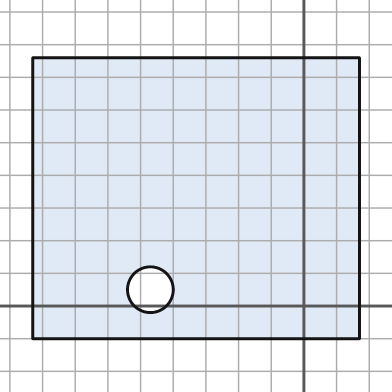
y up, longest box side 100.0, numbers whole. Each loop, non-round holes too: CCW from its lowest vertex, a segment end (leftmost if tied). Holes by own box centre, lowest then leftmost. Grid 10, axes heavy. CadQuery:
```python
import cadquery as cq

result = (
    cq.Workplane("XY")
    .moveTo(-83.0, -10.0)
    .lineTo(17.0, -10.0)
    .lineTo(17.0, 76.0)
    .lineTo(-83.0, 76.0)
    .close()
    .moveTo(-47.0, 5.0)
    .circle(7.0)
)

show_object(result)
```